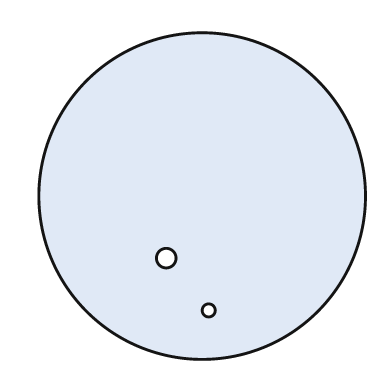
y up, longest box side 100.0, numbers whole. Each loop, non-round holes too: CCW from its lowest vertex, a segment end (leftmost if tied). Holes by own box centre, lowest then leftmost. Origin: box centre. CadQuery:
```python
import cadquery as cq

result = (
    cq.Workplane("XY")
    .moveTo(0.0, 0.0)
    .circle(50.0)
    .moveTo(2.0, -35.0)
    .circle(2.0)
    .moveTo(-11.0, -19.0)
    .circle(3.0)
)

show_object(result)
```